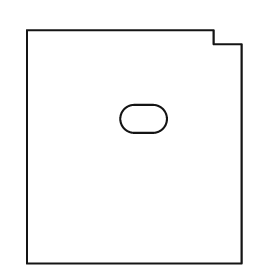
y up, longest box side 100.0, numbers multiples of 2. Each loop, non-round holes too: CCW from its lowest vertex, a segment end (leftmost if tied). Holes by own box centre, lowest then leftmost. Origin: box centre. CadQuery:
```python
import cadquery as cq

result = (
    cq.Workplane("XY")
    .moveTo(-46.0, -50.0)
    .lineTo(46.0, -50.0)
    .lineTo(46.0, 44.0)
    .lineTo(34.0, 44.0)
    .lineTo(34.0, 50.0)
    .lineTo(-46.0, 50.0)
    .close()
    .moveTo(0.0, 6.0)
    .lineTo(8.0, 6.0)
    .threePointArc((14.0, 12.0), (8.0, 18.0))
    .lineTo(0.0, 18.0)
    .threePointArc((-6.0, 12.0), (0.0, 6.0))
    .close()
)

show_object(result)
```